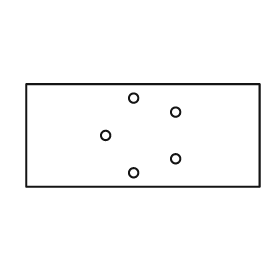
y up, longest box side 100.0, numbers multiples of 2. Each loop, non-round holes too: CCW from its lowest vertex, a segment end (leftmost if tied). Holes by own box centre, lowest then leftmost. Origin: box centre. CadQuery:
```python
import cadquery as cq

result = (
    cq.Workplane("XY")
    .moveTo(-50.0, -22.0)
    .lineTo(50.0, -22.0)
    .lineTo(50.0, 22.0)
    .lineTo(-50.0, 22.0)
    .close()
    .moveTo(-4.0, -16.0)
    .circle(2.0)
    .moveTo(14.0, -10.0)
    .circle(2.0)
    .moveTo(-16.0, 0.0)
    .circle(2.0)
    .moveTo(14.0, 10.0)
    .circle(2.0)
    .moveTo(-4.0, 16.0)
    .circle(2.0)
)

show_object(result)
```